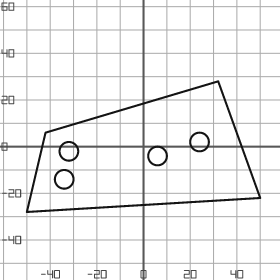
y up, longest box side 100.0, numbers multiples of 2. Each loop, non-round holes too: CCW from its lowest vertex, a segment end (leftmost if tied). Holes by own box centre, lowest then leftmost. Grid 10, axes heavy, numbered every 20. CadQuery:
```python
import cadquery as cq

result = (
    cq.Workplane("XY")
    .moveTo(-50.0, -28.0)
    .lineTo(50.0, -22.0)
    .lineTo(32.0, 28.0)
    .lineTo(-42.0, 6.0)
    .close()
    .moveTo(-34.0, -14.0)
    .circle(4.0)
    .moveTo(6.0, -4.0)
    .circle(4.0)
    .moveTo(-32.0, -2.0)
    .circle(4.0)
    .moveTo(24.0, 2.0)
    .circle(4.0)
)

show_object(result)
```